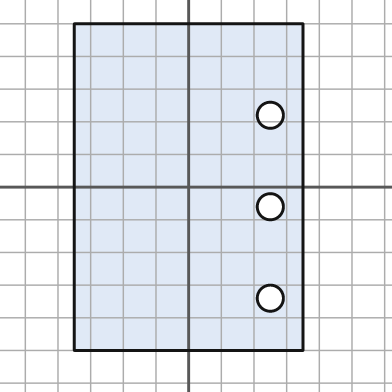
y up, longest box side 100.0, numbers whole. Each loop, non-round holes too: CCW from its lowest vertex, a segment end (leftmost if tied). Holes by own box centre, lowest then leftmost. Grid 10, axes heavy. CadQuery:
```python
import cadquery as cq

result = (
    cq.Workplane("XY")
    .moveTo(-35.0, -50.0)
    .lineTo(35.0, -50.0)
    .lineTo(35.0, 50.0)
    .lineTo(-35.0, 50.0)
    .close()
    .moveTo(25.0, -34.0)
    .circle(4.0)
    .moveTo(25.0, -6.0)
    .circle(4.0)
    .moveTo(25.0, 22.0)
    .circle(4.0)
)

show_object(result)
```